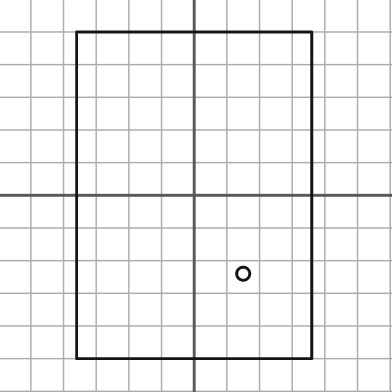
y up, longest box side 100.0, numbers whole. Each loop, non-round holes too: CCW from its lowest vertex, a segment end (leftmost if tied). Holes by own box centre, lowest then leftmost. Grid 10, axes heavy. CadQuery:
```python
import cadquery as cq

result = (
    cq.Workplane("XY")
    .moveTo(-36.0, -50.0)
    .lineTo(36.0, -50.0)
    .lineTo(36.0, 50.0)
    .lineTo(-36.0, 50.0)
    .close()
    .moveTo(15.0, -24.0)
    .circle(2.0)
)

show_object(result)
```